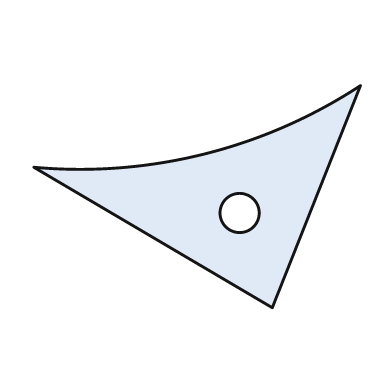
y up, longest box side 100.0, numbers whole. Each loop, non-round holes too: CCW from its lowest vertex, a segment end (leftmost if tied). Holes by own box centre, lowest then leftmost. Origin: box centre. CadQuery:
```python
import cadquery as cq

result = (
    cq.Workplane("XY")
    .moveTo(23.0, -34.0)
    .lineTo(50.0, 34.0)
    .threePointArc((2.0, 13.0), (-50.0, 9.0))
    .close()
    .moveTo(13.0, -5.0)
    .circle(6.0)
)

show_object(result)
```